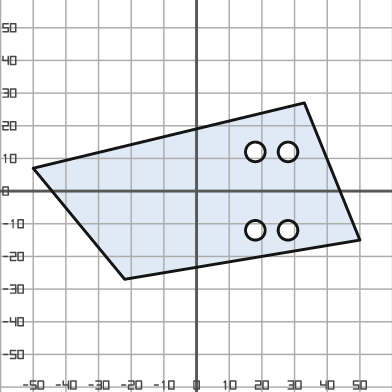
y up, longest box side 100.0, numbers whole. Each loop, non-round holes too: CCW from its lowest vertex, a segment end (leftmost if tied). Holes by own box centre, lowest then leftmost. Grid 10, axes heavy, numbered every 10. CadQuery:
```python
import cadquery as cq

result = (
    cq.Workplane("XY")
    .moveTo(-22.0, -27.0)
    .lineTo(50.0, -15.0)
    .lineTo(33.0, 27.0)
    .lineTo(-50.0, 7.0)
    .close()
    .moveTo(18.0, -12.0)
    .circle(3.0)
    .moveTo(28.0, -12.0)
    .circle(3.0)
    .moveTo(18.0, 12.0)
    .circle(3.0)
    .moveTo(28.0, 12.0)
    .circle(3.0)
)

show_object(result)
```